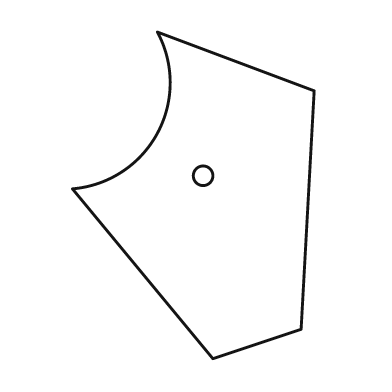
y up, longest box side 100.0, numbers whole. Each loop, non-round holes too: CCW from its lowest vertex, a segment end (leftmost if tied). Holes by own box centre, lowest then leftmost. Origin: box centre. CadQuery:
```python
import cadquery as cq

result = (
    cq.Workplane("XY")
    .moveTo(6.0, -50.0)
    .lineTo(33.0, -41.0)
    .lineTo(37.0, 32.0)
    .lineTo(-11.0, 50.0)
    .threePointArc((-11.0, 19.0), (-37.0, 2.0))
    .close()
    .moveTo(3.0, 6.0)
    .circle(3.0)
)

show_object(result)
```